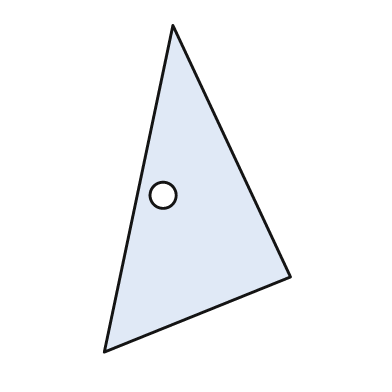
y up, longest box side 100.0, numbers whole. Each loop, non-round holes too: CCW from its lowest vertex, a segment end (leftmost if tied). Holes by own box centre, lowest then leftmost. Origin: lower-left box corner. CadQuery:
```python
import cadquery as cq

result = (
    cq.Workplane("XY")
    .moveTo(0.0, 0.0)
    .lineTo(57.0, 23.0)
    .lineTo(21.0, 100.0)
    .close()
    .moveTo(18.0, 48.0)
    .circle(4.0)
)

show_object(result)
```